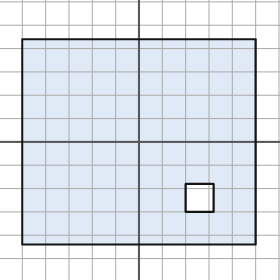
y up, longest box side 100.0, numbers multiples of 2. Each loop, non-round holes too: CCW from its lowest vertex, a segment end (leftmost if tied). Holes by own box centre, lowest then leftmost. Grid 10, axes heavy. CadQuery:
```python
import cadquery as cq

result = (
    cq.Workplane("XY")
    .moveTo(-50.0, -44.0)
    .lineTo(50.0, -44.0)
    .lineTo(50.0, 44.0)
    .lineTo(-50.0, 44.0)
    .close()
    .moveTo(20.0, -30.0)
    .lineTo(32.0, -30.0)
    .lineTo(32.0, -18.0)
    .lineTo(20.0, -18.0)
    .close()
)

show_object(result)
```